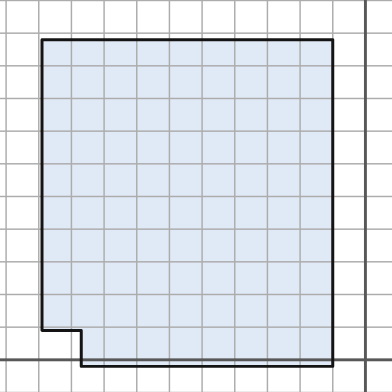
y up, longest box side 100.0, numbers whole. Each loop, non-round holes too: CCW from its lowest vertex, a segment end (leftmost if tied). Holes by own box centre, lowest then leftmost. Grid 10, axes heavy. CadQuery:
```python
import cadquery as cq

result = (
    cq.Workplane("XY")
    .moveTo(-87.0, -2.0)
    .lineTo(-10.0, -2.0)
    .lineTo(-10.0, 98.0)
    .lineTo(-99.0, 98.0)
    .lineTo(-99.0, 9.0)
    .lineTo(-87.0, 9.0)
    .close()
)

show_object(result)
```